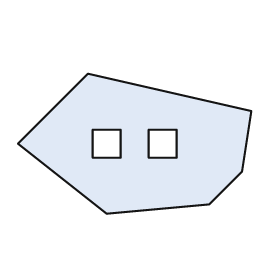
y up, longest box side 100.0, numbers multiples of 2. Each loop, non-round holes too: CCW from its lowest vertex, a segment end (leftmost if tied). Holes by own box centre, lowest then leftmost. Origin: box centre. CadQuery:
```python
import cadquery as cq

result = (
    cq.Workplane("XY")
    .moveTo(-12.0, -30.0)
    .lineTo(32.0, -26.0)
    .lineTo(46.0, -12.0)
    .lineTo(50.0, 14.0)
    .lineTo(-20.0, 30.0)
    .lineTo(-50.0, 0.0)
    .close()
    .moveTo(-18.0, -6.0)
    .lineTo(-6.0, -6.0)
    .lineTo(-6.0, 6.0)
    .lineTo(-18.0, 6.0)
    .close()
    .moveTo(6.0, -6.0)
    .lineTo(18.0, -6.0)
    .lineTo(18.0, 6.0)
    .lineTo(6.0, 6.0)
    .close()
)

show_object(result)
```